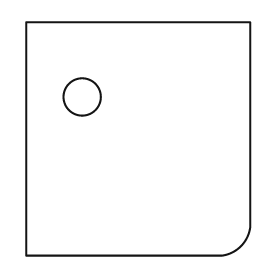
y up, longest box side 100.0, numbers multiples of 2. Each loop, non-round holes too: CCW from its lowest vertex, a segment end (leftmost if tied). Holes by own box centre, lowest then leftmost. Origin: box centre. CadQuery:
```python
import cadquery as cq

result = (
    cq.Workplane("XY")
    .moveTo(-48.0, -50.0)
    .lineTo(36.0, -50.0)
    .threePointArc((44.0, -46.0), (48.0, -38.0))
    .lineTo(48.0, 50.0)
    .lineTo(-48.0, 50.0)
    .close()
    .moveTo(-24.0, 18.0)
    .circle(8.0)
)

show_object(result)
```